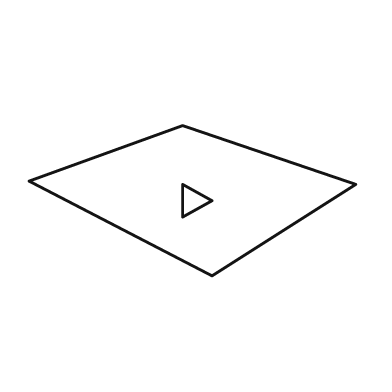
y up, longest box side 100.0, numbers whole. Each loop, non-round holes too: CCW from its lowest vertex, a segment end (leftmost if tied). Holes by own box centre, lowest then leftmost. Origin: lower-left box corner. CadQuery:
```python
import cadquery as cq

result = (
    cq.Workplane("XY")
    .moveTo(56.0, 0.0)
    .lineTo(100.0, 28.0)
    .lineTo(47.0, 46.0)
    .lineTo(0.0, 29.0)
    .close()
    .moveTo(47.0, 18.0)
    .lineTo(56.0, 23.0)
    .lineTo(47.0, 28.0)
    .close()
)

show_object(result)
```